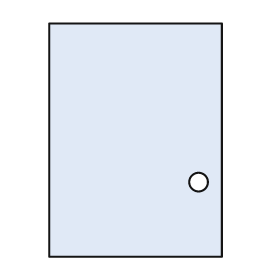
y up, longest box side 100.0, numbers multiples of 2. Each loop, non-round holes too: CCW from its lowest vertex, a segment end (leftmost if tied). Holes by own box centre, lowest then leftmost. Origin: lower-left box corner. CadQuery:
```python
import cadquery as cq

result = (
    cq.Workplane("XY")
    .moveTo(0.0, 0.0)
    .lineTo(74.0, 0.0)
    .lineTo(74.0, 100.0)
    .lineTo(0.0, 100.0)
    .close()
    .moveTo(64.0, 32.0)
    .circle(4.0)
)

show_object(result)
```